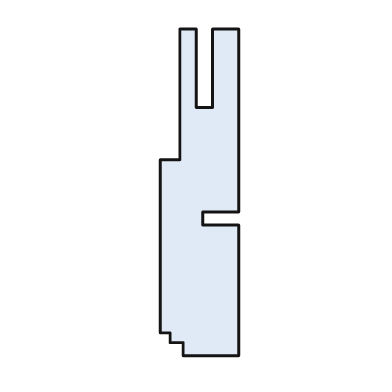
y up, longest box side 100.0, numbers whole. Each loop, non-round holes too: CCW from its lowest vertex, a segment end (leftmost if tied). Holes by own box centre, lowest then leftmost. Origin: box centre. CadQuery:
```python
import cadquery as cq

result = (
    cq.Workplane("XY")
    .moveTo(-5.0, -50.0)
    .lineTo(12.0, -50.0)
    .lineTo(12.0, -10.0)
    .lineTo(1.0, -10.0)
    .lineTo(1.0, -6.0)
    .lineTo(12.0, -6.0)
    .lineTo(12.0, 50.0)
    .lineTo(4.0, 50.0)
    .lineTo(4.0, 26.0)
    .lineTo(-1.0, 26.0)
    .lineTo(-1.0, 50.0)
    .lineTo(-6.0, 50.0)
    .lineTo(-6.0, 10.0)
    .lineTo(-12.0, 10.0)
    .lineTo(-12.0, -43.0)
    .lineTo(-9.0, -43.0)
    .lineTo(-9.0, -46.0)
    .lineTo(-5.0, -46.0)
    .close()
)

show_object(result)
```